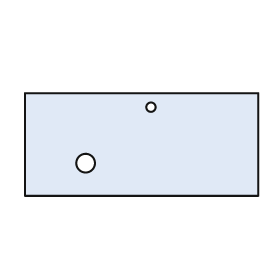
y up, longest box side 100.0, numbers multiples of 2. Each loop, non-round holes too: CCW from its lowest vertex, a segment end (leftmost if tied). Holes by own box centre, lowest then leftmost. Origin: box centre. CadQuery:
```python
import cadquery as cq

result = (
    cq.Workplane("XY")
    .moveTo(-50.0, -22.0)
    .lineTo(50.0, -22.0)
    .lineTo(50.0, 22.0)
    .lineTo(-50.0, 22.0)
    .close()
    .moveTo(-24.0, -8.0)
    .circle(4.0)
    .moveTo(4.0, 16.0)
    .circle(2.0)
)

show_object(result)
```